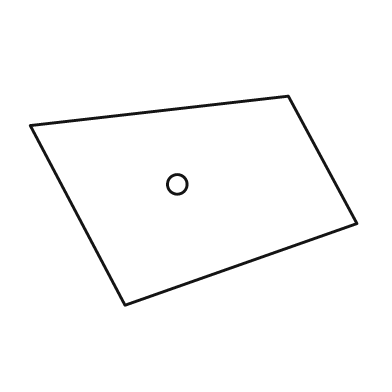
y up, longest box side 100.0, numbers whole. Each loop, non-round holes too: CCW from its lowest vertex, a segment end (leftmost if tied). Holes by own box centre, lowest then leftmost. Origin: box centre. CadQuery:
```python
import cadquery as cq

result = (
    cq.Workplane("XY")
    .moveTo(-21.0, -32.0)
    .lineTo(50.0, -7.0)
    .lineTo(29.0, 32.0)
    .lineTo(-50.0, 23.0)
    .close()
    .moveTo(-5.0, 5.0)
    .circle(3.0)
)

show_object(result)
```